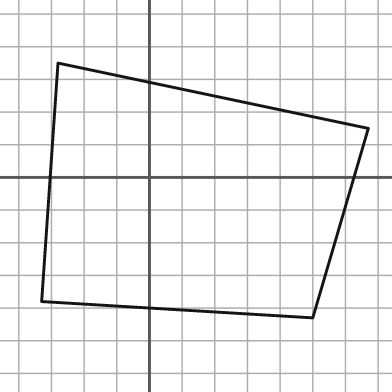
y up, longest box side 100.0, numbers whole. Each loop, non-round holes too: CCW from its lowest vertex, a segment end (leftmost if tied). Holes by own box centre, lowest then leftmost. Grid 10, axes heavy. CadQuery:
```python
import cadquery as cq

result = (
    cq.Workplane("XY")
    .moveTo(50.0, -43.0)
    .lineTo(67.0, 15.0)
    .lineTo(-28.0, 35.0)
    .lineTo(-33.0, -38.0)
    .close()
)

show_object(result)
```